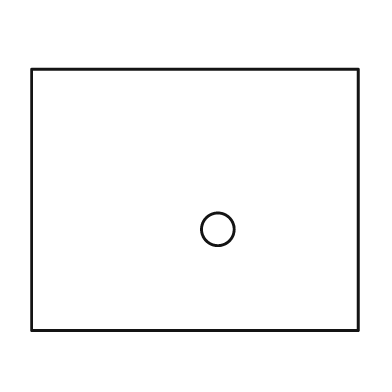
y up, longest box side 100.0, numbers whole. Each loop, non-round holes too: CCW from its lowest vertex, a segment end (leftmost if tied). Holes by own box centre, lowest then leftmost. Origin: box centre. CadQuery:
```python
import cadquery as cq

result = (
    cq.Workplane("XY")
    .moveTo(-50.0, -40.0)
    .lineTo(50.0, -40.0)
    .lineTo(50.0, 40.0)
    .lineTo(-50.0, 40.0)
    .close()
    .moveTo(7.0, -9.0)
    .circle(5.0)
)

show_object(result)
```